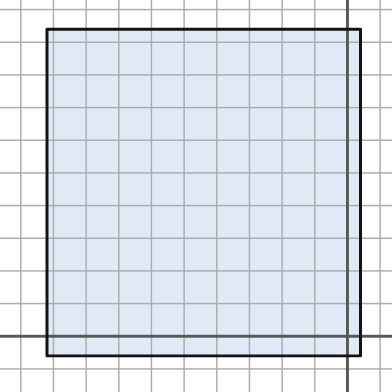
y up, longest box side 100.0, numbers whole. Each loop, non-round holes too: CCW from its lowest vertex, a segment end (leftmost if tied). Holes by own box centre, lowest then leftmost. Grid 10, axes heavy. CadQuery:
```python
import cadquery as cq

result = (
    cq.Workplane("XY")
    .moveTo(-92.0, -6.0)
    .lineTo(4.0, -6.0)
    .lineTo(4.0, 94.0)
    .lineTo(-92.0, 94.0)
    .close()
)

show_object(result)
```